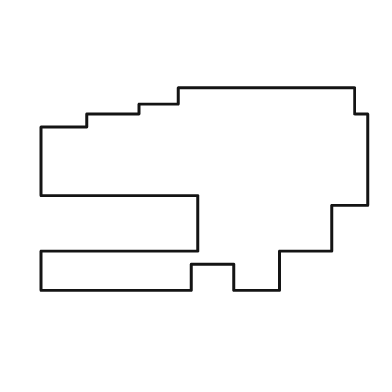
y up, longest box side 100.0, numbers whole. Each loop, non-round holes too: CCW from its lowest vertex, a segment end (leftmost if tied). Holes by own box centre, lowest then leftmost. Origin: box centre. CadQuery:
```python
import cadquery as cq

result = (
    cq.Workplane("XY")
    .moveTo(-50.0, -31.0)
    .lineTo(-4.0, -31.0)
    .lineTo(-4.0, -23.0)
    .lineTo(9.0, -23.0)
    .lineTo(9.0, -31.0)
    .lineTo(23.0, -31.0)
    .lineTo(23.0, -19.0)
    .lineTo(39.0, -19.0)
    .lineTo(39.0, -5.0)
    .lineTo(50.0, -5.0)
    .lineTo(50.0, 23.0)
    .lineTo(46.0, 23.0)
    .lineTo(46.0, 31.0)
    .lineTo(-8.0, 31.0)
    .lineTo(-8.0, 26.0)
    .lineTo(-20.0, 26.0)
    .lineTo(-20.0, 23.0)
    .lineTo(-36.0, 23.0)
    .lineTo(-36.0, 19.0)
    .lineTo(-50.0, 19.0)
    .lineTo(-50.0, -2.0)
    .lineTo(-2.0, -2.0)
    .lineTo(-2.0, -19.0)
    .lineTo(-50.0, -19.0)
    .close()
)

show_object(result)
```